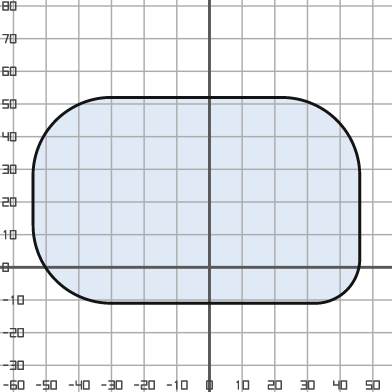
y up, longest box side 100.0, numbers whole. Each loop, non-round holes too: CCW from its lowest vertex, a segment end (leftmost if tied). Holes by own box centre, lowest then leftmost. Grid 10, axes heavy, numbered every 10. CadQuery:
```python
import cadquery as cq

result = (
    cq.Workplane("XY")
    .moveTo(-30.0, -11.0)
    .lineTo(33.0, -11.0)
    .threePointArc((42.0, -7.0), (46.0, 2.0))
    .lineTo(46.0, 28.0)
    .threePointArc((39.0, 45.0), (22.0, 52.0))
    .lineTo(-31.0, 52.0)
    .threePointArc((-47.0, 45.0), (-54.0, 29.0))
    .lineTo(-54.0, 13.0)
    .threePointArc((-47.0, -4.0), (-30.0, -11.0))
    .close()
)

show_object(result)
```